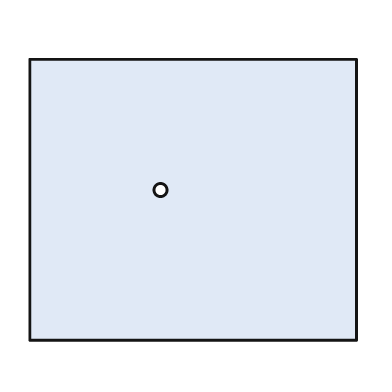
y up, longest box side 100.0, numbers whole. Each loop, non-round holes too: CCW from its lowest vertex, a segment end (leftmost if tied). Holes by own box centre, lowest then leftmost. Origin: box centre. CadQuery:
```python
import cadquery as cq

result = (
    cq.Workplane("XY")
    .moveTo(-50.0, -43.0)
    .lineTo(50.0, -43.0)
    .lineTo(50.0, 43.0)
    .lineTo(-50.0, 43.0)
    .close()
    .moveTo(-10.0, 3.0)
    .circle(2.0)
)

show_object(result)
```